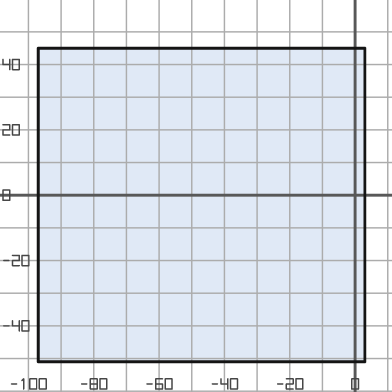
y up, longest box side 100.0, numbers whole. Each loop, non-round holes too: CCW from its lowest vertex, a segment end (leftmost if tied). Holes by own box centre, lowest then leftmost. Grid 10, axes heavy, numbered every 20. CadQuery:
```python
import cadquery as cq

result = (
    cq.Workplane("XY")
    .moveTo(-97.0, -51.0)
    .lineTo(3.0, -51.0)
    .lineTo(3.0, 45.0)
    .lineTo(-97.0, 45.0)
    .close()
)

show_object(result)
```